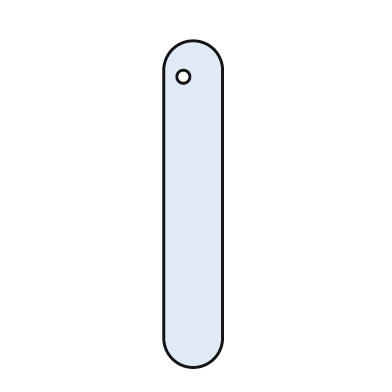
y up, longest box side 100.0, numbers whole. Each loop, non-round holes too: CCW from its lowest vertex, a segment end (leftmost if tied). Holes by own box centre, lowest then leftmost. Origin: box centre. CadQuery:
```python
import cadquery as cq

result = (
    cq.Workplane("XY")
    .moveTo(-9.0, -41.0)
    .threePointArc((0.0, -50.0), (9.0, -41.0))
    .lineTo(9.0, 41.0)
    .threePointArc((0.0, 50.0), (-9.0, 41.0))
    .close()
    .moveTo(-3.0, 39.0)
    .circle(2.0)
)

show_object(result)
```